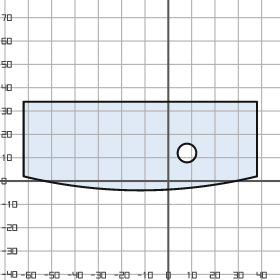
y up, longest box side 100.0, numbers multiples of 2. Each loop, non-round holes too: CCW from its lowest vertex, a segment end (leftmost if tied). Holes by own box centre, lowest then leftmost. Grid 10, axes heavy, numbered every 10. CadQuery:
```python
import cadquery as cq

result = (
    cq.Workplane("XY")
    .moveTo(-62.0, 2.0)
    .threePointArc((-12.0, -4.0), (38.0, 2.0))
    .lineTo(38.0, 34.0)
    .lineTo(-62.0, 34.0)
    .close()
    .moveTo(8.0, 12.0)
    .circle(4.0)
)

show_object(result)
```